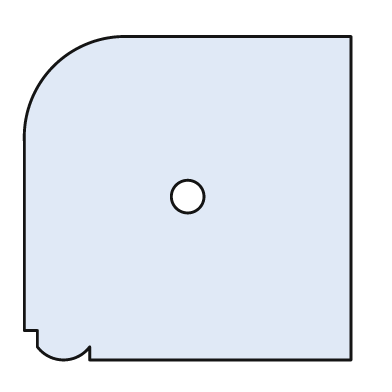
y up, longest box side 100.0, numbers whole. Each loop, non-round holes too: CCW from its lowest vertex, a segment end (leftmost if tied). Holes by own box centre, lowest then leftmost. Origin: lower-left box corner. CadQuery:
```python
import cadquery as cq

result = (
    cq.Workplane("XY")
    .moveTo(20.0, 0.0)
    .lineTo(100.0, 0.0)
    .lineTo(100.0, 99.0)
    .lineTo(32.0, 99.0)
    .threePointArc((9.0, 90.0), (0.0, 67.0))
    .lineTo(0.0, 9.0)
    .lineTo(4.0, 9.0)
    .lineTo(4.0, 4.0)
    .threePointArc((12.0, 0.0), (20.0, 4.0))
    .close()
    .moveTo(50.0, 50.0)
    .circle(5.0)
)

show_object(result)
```